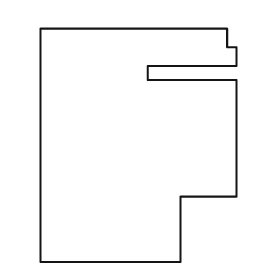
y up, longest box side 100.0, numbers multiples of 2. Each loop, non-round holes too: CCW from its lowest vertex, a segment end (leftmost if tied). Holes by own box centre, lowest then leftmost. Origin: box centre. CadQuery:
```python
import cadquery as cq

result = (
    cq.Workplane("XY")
    .moveTo(-42.0, -50.0)
    .lineTo(18.0, -50.0)
    .lineTo(18.0, -22.0)
    .lineTo(42.0, -22.0)
    .lineTo(42.0, 28.0)
    .lineTo(4.0, 28.0)
    .lineTo(4.0, 34.0)
    .lineTo(42.0, 34.0)
    .lineTo(42.0, 42.0)
    .lineTo(38.0, 42.0)
    .lineTo(38.0, 50.0)
    .lineTo(-42.0, 50.0)
    .close()
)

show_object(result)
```